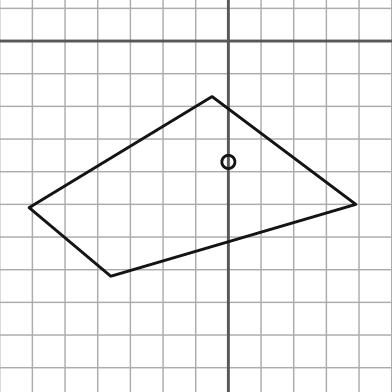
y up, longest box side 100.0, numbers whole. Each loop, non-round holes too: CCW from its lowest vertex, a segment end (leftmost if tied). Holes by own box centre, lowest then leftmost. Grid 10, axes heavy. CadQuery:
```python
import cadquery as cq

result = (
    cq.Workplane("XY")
    .moveTo(-36.0, -72.0)
    .lineTo(39.0, -50.0)
    .lineTo(-5.0, -17.0)
    .lineTo(-61.0, -51.0)
    .close()
    .moveTo(0.0, -37.0)
    .circle(2.0)
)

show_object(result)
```